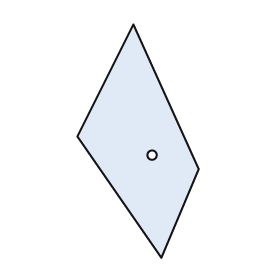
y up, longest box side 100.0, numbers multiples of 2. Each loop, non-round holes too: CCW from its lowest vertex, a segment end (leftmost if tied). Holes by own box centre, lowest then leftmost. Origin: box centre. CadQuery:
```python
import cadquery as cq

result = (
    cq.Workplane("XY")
    .moveTo(10.0, -50.0)
    .lineTo(26.0, -12.0)
    .lineTo(-2.0, 50.0)
    .lineTo(-26.0, 2.0)
    .close()
    .moveTo(6.0, -6.0)
    .circle(2.0)
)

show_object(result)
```